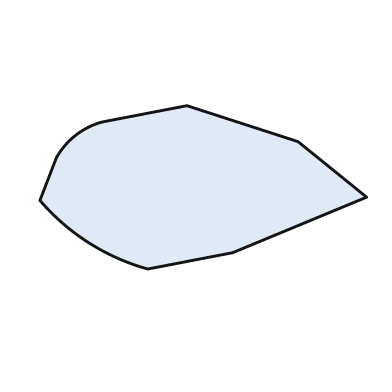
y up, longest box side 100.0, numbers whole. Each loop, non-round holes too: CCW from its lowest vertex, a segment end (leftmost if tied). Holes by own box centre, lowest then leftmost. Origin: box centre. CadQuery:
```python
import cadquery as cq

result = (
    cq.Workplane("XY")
    .moveTo(-17.0, -25.0)
    .lineTo(9.0, -20.0)
    .lineTo(50.0, -3.0)
    .lineTo(29.0, 14.0)
    .lineTo(-5.0, 25.0)
    .lineTo(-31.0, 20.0)
    .threePointArc((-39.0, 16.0), (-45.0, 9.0))
    .lineTo(-50.0, -4.0)
    .threePointArc((-35.0, -17.0), (-17.0, -25.0))
    .close()
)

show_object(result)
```